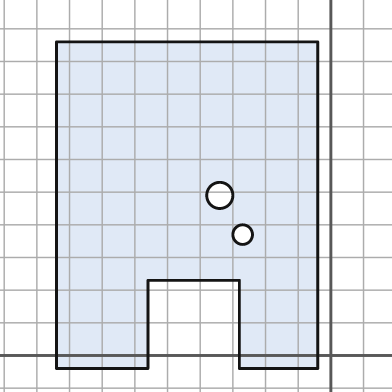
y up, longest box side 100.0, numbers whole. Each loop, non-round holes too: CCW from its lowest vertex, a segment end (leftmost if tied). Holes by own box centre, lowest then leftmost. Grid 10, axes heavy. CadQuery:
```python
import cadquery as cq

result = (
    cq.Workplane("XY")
    .moveTo(-84.0, -4.0)
    .lineTo(-56.0, -4.0)
    .lineTo(-56.0, 23.0)
    .lineTo(-28.0, 23.0)
    .lineTo(-28.0, -4.0)
    .lineTo(-4.0, -4.0)
    .lineTo(-4.0, 96.0)
    .lineTo(-84.0, 96.0)
    .close()
    .moveTo(-27.0, 37.0)
    .circle(3.0)
    .moveTo(-34.0, 49.0)
    .circle(4.0)
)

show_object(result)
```